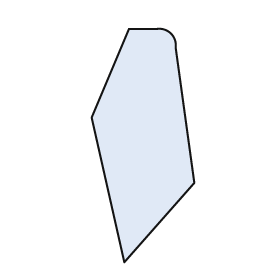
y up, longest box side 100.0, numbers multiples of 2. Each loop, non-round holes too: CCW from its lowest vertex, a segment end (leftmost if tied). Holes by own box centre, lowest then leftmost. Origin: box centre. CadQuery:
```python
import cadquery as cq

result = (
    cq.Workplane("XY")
    .moveTo(-8.0, -50.0)
    .lineTo(22.0, -16.0)
    .lineTo(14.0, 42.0)
    .threePointArc((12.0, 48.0), (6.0, 50.0))
    .lineTo(-6.0, 50.0)
    .lineTo(-22.0, 12.0)
    .close()
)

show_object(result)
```